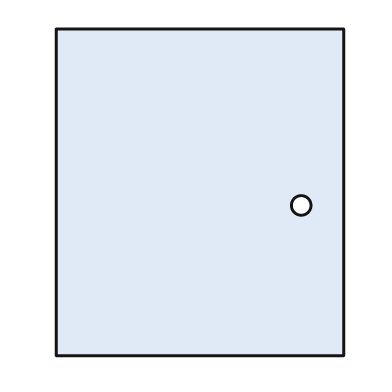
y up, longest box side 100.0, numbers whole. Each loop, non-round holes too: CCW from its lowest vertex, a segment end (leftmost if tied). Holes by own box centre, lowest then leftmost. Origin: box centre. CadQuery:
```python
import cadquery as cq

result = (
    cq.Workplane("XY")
    .moveTo(-44.0, -50.0)
    .lineTo(44.0, -50.0)
    .lineTo(44.0, 50.0)
    .lineTo(-44.0, 50.0)
    .close()
    .moveTo(31.0, -4.0)
    .circle(3.0)
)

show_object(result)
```